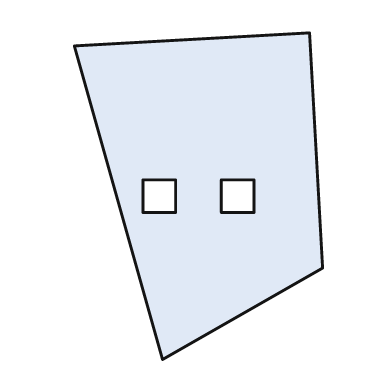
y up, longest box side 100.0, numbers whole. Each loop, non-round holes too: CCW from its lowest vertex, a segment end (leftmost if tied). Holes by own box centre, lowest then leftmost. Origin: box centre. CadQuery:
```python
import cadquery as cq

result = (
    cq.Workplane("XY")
    .moveTo(-11.0, -50.0)
    .lineTo(38.0, -22.0)
    .lineTo(34.0, 50.0)
    .lineTo(-38.0, 46.0)
    .close()
    .moveTo(-17.0, -5.0)
    .lineTo(-7.0, -5.0)
    .lineTo(-7.0, 5.0)
    .lineTo(-17.0, 5.0)
    .close()
    .moveTo(7.0, -5.0)
    .lineTo(17.0, -5.0)
    .lineTo(17.0, 5.0)
    .lineTo(7.0, 5.0)
    .close()
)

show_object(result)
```